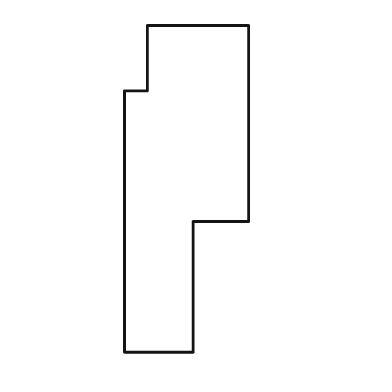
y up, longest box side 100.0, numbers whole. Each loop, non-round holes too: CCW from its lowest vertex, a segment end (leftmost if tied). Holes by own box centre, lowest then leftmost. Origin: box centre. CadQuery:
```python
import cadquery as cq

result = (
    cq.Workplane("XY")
    .moveTo(-19.0, -50.0)
    .lineTo(2.0, -50.0)
    .lineTo(2.0, -10.0)
    .lineTo(19.0, -10.0)
    .lineTo(19.0, 50.0)
    .lineTo(-12.0, 50.0)
    .lineTo(-12.0, 30.0)
    .lineTo(-19.0, 30.0)
    .close()
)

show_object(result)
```